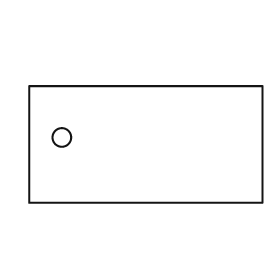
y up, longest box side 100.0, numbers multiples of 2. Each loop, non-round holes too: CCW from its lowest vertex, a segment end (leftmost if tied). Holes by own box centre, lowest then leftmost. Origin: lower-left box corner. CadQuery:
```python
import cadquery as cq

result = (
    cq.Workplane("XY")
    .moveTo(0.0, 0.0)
    .lineTo(100.0, 0.0)
    .lineTo(100.0, 50.0)
    .lineTo(0.0, 50.0)
    .close()
    .moveTo(14.0, 28.0)
    .circle(4.0)
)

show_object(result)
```